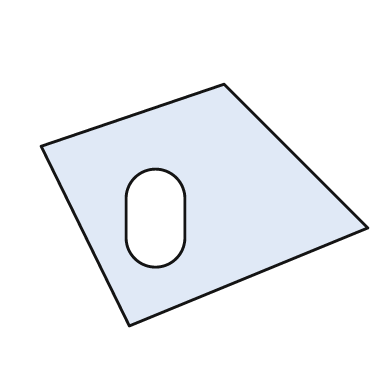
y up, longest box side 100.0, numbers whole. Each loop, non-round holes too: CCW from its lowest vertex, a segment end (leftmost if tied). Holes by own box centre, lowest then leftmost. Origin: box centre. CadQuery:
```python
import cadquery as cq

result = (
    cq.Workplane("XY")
    .moveTo(-23.0, -37.0)
    .lineTo(50.0, -7.0)
    .lineTo(6.0, 37.0)
    .lineTo(-50.0, 18.0)
    .close()
    .moveTo(-24.0, -10.0)
    .threePointArc((-15.0, -19.0), (-6.0, -10.0))
    .lineTo(-6.0, 2.0)
    .threePointArc((-15.0, 11.0), (-24.0, 2.0))
    .close()
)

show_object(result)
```